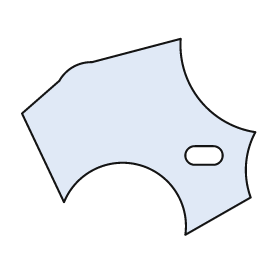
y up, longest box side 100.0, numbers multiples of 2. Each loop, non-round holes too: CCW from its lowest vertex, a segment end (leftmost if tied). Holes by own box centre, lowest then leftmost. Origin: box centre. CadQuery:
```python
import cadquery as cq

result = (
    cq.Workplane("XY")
    .moveTo(20.0, -42.0)
    .lineTo(48.0, -26.0)
    .threePointArc((46.0, -12.0), (50.0, 2.0))
    .threePointArc((26.0, 16.0), (18.0, 42.0))
    .lineTo(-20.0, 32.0)
    .threePointArc((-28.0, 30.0), (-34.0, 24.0))
    .lineTo(-50.0, 10.0)
    .lineTo(-32.0, -28.0)
    .threePointArc((0.0, -12.0), (20.0, -42.0))
    .close()
    .moveTo(24.0, -12.0)
    .lineTo(32.0, -12.0)
    .threePointArc((36.0, -8.0), (32.0, -4.0))
    .lineTo(24.0, -4.0)
    .threePointArc((20.0, -8.0), (24.0, -12.0))
    .close()
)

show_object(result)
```